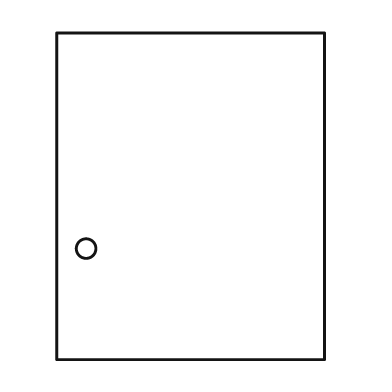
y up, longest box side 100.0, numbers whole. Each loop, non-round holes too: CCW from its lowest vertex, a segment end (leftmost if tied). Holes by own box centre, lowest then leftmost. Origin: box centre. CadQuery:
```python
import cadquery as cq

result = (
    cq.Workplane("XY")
    .moveTo(-41.0, -50.0)
    .lineTo(41.0, -50.0)
    .lineTo(41.0, 50.0)
    .lineTo(-41.0, 50.0)
    .close()
    .moveTo(-32.0, -16.0)
    .circle(3.0)
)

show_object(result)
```